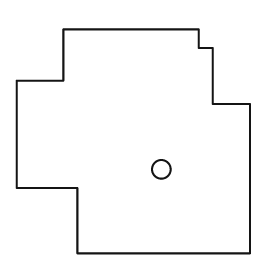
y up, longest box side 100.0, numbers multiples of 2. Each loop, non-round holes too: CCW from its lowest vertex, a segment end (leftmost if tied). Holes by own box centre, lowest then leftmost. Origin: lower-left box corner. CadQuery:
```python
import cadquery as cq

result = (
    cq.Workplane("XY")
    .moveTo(26.0, 0.0)
    .lineTo(100.0, 0.0)
    .lineTo(100.0, 64.0)
    .lineTo(84.0, 64.0)
    .lineTo(84.0, 88.0)
    .lineTo(78.0, 88.0)
    .lineTo(78.0, 96.0)
    .lineTo(20.0, 96.0)
    .lineTo(20.0, 74.0)
    .lineTo(0.0, 74.0)
    .lineTo(0.0, 28.0)
    .lineTo(26.0, 28.0)
    .close()
    .moveTo(62.0, 36.0)
    .circle(4.0)
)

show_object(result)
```